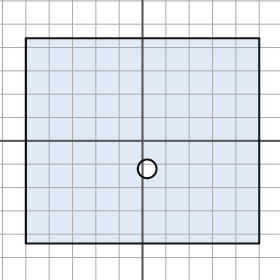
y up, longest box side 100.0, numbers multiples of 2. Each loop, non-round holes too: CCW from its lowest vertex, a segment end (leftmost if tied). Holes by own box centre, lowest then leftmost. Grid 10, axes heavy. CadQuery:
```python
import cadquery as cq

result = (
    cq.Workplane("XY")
    .moveTo(-50.0, -44.0)
    .lineTo(50.0, -44.0)
    .lineTo(50.0, 44.0)
    .lineTo(-50.0, 44.0)
    .close()
    .moveTo(2.0, -12.0)
    .circle(4.0)
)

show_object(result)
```